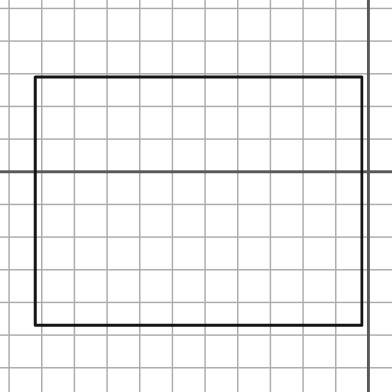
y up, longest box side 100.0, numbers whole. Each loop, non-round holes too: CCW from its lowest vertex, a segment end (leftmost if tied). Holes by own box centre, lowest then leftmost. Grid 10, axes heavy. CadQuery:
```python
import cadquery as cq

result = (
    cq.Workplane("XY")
    .moveTo(-102.0, -47.0)
    .lineTo(-2.0, -47.0)
    .lineTo(-2.0, 29.0)
    .lineTo(-102.0, 29.0)
    .close()
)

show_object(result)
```